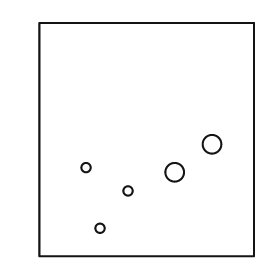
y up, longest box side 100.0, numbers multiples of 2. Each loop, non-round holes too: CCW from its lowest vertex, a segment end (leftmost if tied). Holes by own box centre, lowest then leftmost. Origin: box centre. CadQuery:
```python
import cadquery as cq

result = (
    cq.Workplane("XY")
    .moveTo(-46.0, -50.0)
    .lineTo(46.0, -50.0)
    .lineTo(46.0, 50.0)
    .lineTo(-46.0, 50.0)
    .close()
    .moveTo(-20.0, -38.0)
    .circle(2.0)
    .moveTo(-8.0, -22.0)
    .circle(2.0)
    .moveTo(12.0, -14.0)
    .circle(4.0)
    .moveTo(-26.0, -12.0)
    .circle(2.0)
    .moveTo(28.0, -2.0)
    .circle(4.0)
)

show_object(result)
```